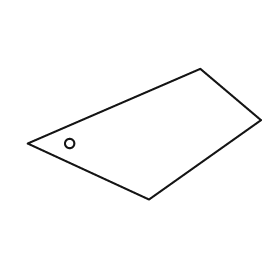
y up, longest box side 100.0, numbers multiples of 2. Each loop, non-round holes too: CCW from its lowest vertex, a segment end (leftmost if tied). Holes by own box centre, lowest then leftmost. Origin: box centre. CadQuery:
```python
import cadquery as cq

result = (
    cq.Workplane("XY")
    .moveTo(2.0, -28.0)
    .lineTo(50.0, 6.0)
    .lineTo(24.0, 28.0)
    .lineTo(-50.0, -4.0)
    .close()
    .moveTo(-32.0, -4.0)
    .circle(2.0)
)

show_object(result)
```